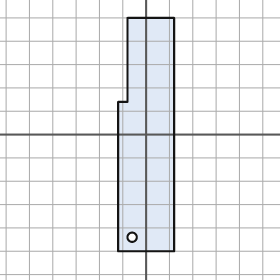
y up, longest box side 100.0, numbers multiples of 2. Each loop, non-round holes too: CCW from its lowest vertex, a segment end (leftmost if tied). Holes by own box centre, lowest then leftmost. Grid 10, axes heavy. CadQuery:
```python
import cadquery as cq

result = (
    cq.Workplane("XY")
    .moveTo(-12.0, -50.0)
    .lineTo(12.0, -50.0)
    .lineTo(12.0, 50.0)
    .lineTo(-8.0, 50.0)
    .lineTo(-8.0, 14.0)
    .lineTo(-12.0, 14.0)
    .close()
    .moveTo(-6.0, -44.0)
    .circle(2.0)
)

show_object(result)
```